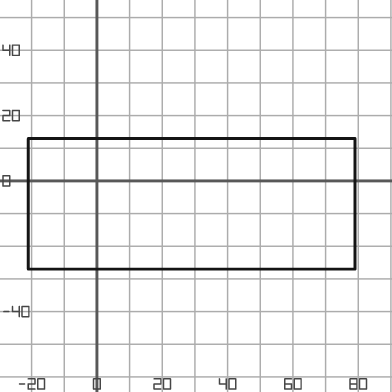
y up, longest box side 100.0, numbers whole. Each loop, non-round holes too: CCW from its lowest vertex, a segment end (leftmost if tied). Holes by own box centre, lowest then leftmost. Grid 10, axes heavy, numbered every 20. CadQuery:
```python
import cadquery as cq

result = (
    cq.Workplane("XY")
    .moveTo(-21.0, -27.0)
    .lineTo(79.0, -27.0)
    .lineTo(79.0, 13.0)
    .lineTo(-21.0, 13.0)
    .close()
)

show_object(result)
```